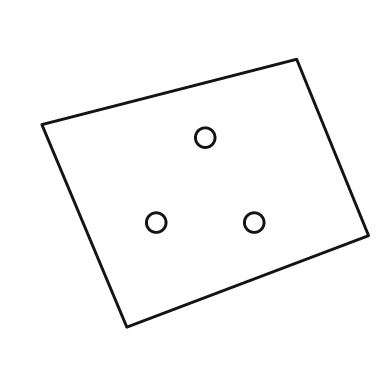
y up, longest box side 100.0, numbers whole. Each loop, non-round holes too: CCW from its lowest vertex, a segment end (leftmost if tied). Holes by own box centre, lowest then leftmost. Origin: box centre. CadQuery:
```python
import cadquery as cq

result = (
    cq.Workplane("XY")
    .moveTo(-24.0, -41.0)
    .lineTo(50.0, -13.0)
    .lineTo(28.0, 41.0)
    .lineTo(-50.0, 21.0)
    .close()
    .moveTo(-15.0, -9.0)
    .circle(3.0)
    .moveTo(15.0, -9.0)
    .circle(3.0)
    .moveTo(0.0, 17.0)
    .circle(3.0)
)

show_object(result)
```